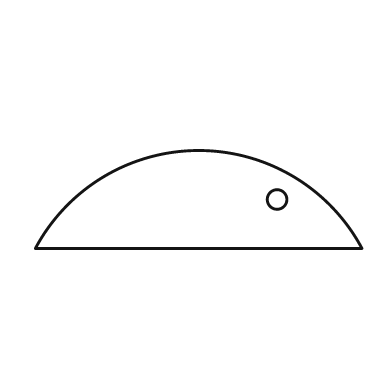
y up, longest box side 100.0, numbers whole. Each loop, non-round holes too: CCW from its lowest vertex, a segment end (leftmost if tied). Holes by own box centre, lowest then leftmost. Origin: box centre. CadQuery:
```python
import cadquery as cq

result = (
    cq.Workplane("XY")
    .moveTo(-50.0, -15.0)
    .lineTo(50.0, -15.0)
    .threePointArc((0.0, 15.0), (-50.0, -15.0))
    .close()
    .moveTo(24.0, 0.0)
    .circle(3.0)
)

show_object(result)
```